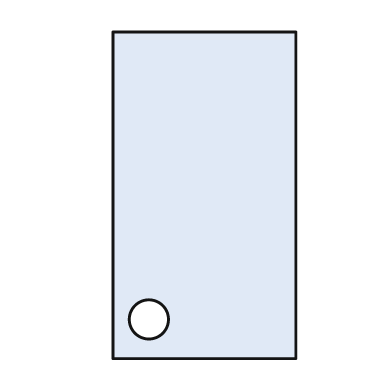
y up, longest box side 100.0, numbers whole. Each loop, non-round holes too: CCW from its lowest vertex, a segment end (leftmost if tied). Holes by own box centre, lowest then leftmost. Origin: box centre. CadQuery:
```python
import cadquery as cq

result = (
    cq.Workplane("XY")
    .moveTo(-28.0, -50.0)
    .lineTo(28.0, -50.0)
    .lineTo(28.0, 50.0)
    .lineTo(-28.0, 50.0)
    .close()
    .moveTo(-17.0, -38.0)
    .circle(6.0)
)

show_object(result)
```